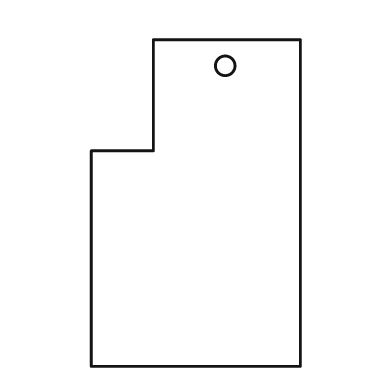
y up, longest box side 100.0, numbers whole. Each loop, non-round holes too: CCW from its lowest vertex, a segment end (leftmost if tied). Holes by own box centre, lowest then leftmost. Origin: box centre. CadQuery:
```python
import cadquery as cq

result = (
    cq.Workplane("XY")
    .moveTo(-32.0, -50.0)
    .lineTo(32.0, -50.0)
    .lineTo(32.0, 50.0)
    .lineTo(-13.0, 50.0)
    .lineTo(-13.0, 16.0)
    .lineTo(-32.0, 16.0)
    .close()
    .moveTo(9.0, 42.0)
    .circle(3.0)
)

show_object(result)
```